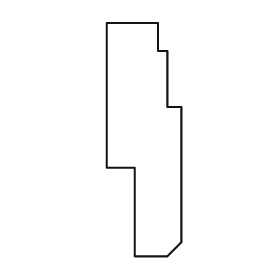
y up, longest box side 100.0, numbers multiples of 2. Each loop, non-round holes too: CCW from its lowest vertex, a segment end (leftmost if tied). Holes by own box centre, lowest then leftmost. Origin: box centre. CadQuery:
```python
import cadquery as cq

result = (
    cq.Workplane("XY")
    .moveTo(-4.0, -50.0)
    .lineTo(10.0, -50.0)
    .lineTo(16.0, -44.0)
    .lineTo(16.0, 14.0)
    .lineTo(10.0, 14.0)
    .lineTo(10.0, 38.0)
    .lineTo(6.0, 38.0)
    .lineTo(6.0, 50.0)
    .lineTo(-16.0, 50.0)
    .lineTo(-16.0, -12.0)
    .lineTo(-4.0, -12.0)
    .close()
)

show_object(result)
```